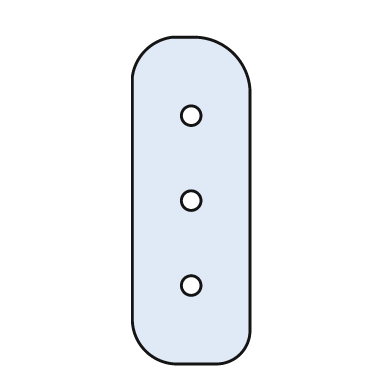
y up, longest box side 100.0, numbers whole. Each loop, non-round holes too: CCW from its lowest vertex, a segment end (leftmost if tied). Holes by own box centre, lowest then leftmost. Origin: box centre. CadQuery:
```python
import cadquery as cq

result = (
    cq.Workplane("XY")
    .moveTo(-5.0, -50.0)
    .lineTo(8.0, -50.0)
    .threePointArc((15.0, -47.0), (18.0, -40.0))
    .lineTo(18.0, 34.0)
    .threePointArc((13.0, 45.0), (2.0, 50.0))
    .lineTo(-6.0, 50.0)
    .threePointArc((-14.0, 46.0), (-18.0, 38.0))
    .lineTo(-18.0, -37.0)
    .threePointArc((-14.0, -46.0), (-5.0, -50.0))
    .close()
    .moveTo(0.0, -26.0)
    .circle(3.0)
    .moveTo(0.0, 0.0)
    .circle(3.0)
    .moveTo(0.0, 26.0)
    .circle(3.0)
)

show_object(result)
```